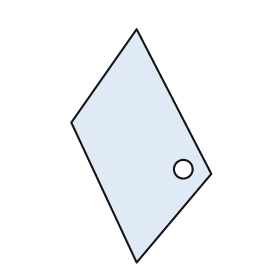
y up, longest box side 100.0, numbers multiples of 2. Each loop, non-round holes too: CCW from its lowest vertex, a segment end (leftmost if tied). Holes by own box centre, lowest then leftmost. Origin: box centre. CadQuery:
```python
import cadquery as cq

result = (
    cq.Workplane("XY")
    .moveTo(-2.0, -50.0)
    .lineTo(30.0, -12.0)
    .lineTo(-2.0, 50.0)
    .lineTo(-30.0, 10.0)
    .close()
    .moveTo(18.0, -10.0)
    .circle(4.0)
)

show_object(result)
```